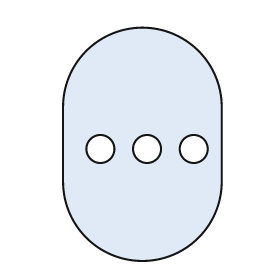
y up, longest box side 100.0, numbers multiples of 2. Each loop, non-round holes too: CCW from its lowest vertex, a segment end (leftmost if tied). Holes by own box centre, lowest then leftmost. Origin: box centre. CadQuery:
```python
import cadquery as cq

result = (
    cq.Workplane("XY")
    .moveTo(-34.0, -16.0)
    .threePointArc((0.0, -50.0), (34.0, -16.0))
    .lineTo(34.0, 16.0)
    .threePointArc((0.0, 50.0), (-34.0, 16.0))
    .close()
    .moveTo(-18.0, -2.0)
    .circle(6.0)
    .moveTo(2.0, -2.0)
    .circle(6.0)
    .moveTo(22.0, -2.0)
    .circle(6.0)
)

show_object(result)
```